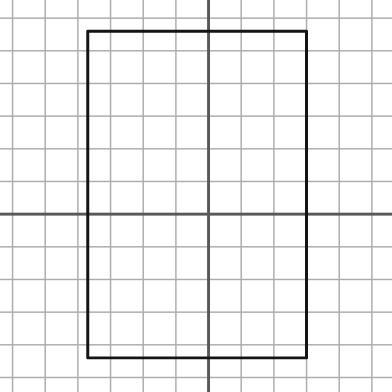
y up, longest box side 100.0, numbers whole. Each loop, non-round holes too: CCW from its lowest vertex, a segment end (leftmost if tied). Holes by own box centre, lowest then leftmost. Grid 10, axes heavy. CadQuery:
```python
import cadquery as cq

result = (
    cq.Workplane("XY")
    .moveTo(-37.0, -44.0)
    .lineTo(30.0, -44.0)
    .lineTo(30.0, 56.0)
    .lineTo(-37.0, 56.0)
    .close()
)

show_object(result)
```